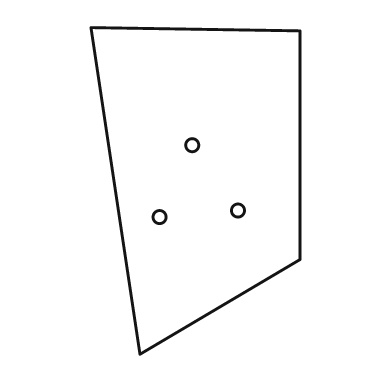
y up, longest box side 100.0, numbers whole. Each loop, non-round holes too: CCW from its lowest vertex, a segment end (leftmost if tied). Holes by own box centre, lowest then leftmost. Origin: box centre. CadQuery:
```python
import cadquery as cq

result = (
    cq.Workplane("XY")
    .moveTo(-17.0, -50.0)
    .lineTo(32.0, -21.0)
    .lineTo(32.0, 49.0)
    .lineTo(-32.0, 50.0)
    .close()
    .moveTo(-11.0, -8.0)
    .circle(2.0)
    .moveTo(13.0, -6.0)
    .circle(2.0)
    .moveTo(-1.0, 14.0)
    .circle(2.0)
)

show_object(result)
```